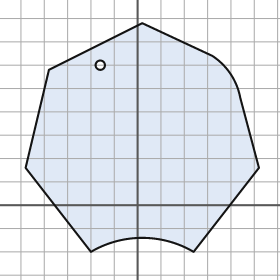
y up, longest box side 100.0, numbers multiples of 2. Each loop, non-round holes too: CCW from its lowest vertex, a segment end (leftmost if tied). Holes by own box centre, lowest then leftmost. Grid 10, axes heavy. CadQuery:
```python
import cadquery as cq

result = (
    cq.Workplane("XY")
    .moveTo(-20.0, -20.0)
    .threePointArc((2.0, -14.0), (24.0, -20.0))
    .lineTo(52.0, 16.0)
    .lineTo(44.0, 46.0)
    .threePointArc((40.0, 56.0), (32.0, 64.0))
    .lineTo(2.0, 78.0)
    .lineTo(-38.0, 58.0)
    .lineTo(-48.0, 16.0)
    .close()
    .moveTo(-16.0, 60.0)
    .circle(2.0)
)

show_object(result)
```